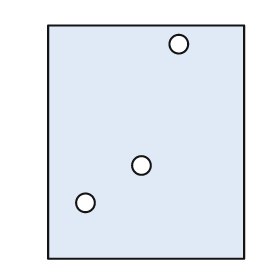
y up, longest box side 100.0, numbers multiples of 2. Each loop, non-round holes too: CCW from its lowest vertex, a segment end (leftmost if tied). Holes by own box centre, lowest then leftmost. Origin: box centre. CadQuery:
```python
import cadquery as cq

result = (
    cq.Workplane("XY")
    .moveTo(-42.0, -50.0)
    .lineTo(42.0, -50.0)
    .lineTo(42.0, 50.0)
    .lineTo(-42.0, 50.0)
    .close()
    .moveTo(-26.0, -26.0)
    .circle(4.0)
    .moveTo(-2.0, -10.0)
    .circle(4.0)
    .moveTo(14.0, 42.0)
    .circle(4.0)
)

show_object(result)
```